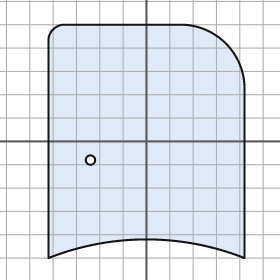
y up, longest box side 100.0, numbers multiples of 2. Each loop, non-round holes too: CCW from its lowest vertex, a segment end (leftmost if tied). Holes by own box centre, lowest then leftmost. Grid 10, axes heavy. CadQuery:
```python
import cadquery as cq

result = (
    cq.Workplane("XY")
    .moveTo(-42.0, -50.0)
    .threePointArc((0.0, -42.0), (42.0, -50.0))
    .lineTo(42.0, 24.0)
    .threePointArc((34.0, 42.0), (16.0, 50.0))
    .lineTo(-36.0, 50.0)
    .threePointArc((-40.0, 48.0), (-42.0, 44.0))
    .close()
    .moveTo(-24.0, -8.0)
    .circle(2.0)
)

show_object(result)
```